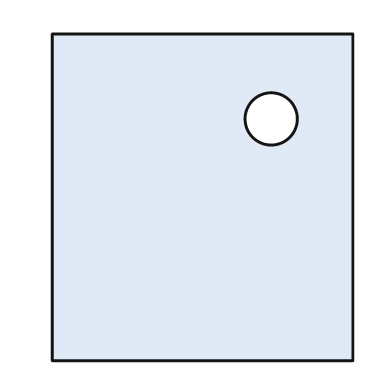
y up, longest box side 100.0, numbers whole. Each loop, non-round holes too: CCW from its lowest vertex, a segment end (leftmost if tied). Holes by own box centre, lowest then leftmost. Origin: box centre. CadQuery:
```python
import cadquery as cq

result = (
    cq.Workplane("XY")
    .moveTo(-46.0, -50.0)
    .lineTo(46.0, -50.0)
    .lineTo(46.0, 50.0)
    .lineTo(-46.0, 50.0)
    .close()
    .moveTo(21.0, 24.0)
    .circle(8.0)
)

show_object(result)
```